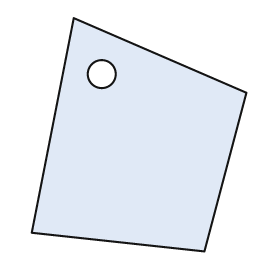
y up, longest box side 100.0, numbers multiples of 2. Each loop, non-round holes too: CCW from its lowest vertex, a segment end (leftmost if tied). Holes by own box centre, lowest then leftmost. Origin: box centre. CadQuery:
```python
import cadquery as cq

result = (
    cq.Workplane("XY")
    .moveTo(28.0, -50.0)
    .lineTo(46.0, 18.0)
    .lineTo(-28.0, 50.0)
    .lineTo(-46.0, -42.0)
    .close()
    .moveTo(-16.0, 26.0)
    .circle(6.0)
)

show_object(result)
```